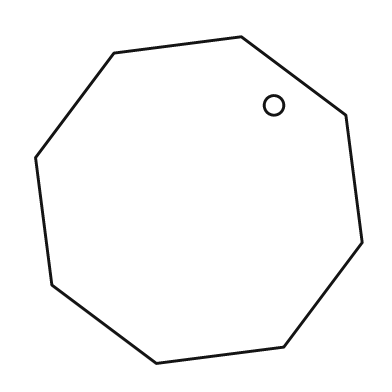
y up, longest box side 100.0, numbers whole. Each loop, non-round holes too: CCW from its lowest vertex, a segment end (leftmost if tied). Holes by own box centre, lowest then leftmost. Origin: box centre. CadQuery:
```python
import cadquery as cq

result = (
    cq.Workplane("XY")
    .moveTo(-13.0, -50.0)
    .lineTo(26.0, -45.0)
    .lineTo(50.0, -13.0)
    .lineTo(45.0, 26.0)
    .lineTo(13.0, 50.0)
    .lineTo(-26.0, 45.0)
    .lineTo(-50.0, 13.0)
    .lineTo(-45.0, -26.0)
    .close()
    .moveTo(23.0, 29.0)
    .circle(3.0)
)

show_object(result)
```